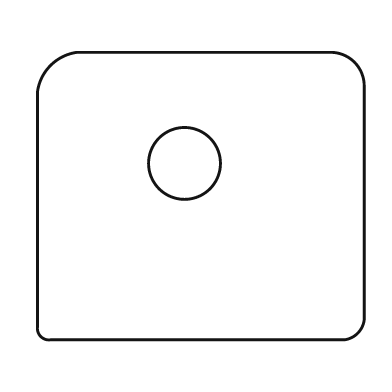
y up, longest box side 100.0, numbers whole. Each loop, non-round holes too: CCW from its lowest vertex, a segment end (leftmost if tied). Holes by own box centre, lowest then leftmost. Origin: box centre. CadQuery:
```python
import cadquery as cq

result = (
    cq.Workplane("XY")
    .moveTo(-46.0, -44.0)
    .lineTo(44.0, -44.0)
    .threePointArc((48.0, -42.0), (50.0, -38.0))
    .lineTo(50.0, 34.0)
    .threePointArc((47.0, 41.0), (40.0, 44.0))
    .lineTo(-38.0, 44.0)
    .threePointArc((-46.0, 40.0), (-50.0, 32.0))
    .lineTo(-50.0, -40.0)
    .threePointArc((-49.0, -43.0), (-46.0, -44.0))
    .close()
    .moveTo(-5.0, 10.0)
    .circle(11.0)
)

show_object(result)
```